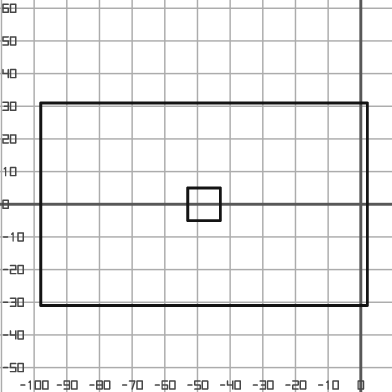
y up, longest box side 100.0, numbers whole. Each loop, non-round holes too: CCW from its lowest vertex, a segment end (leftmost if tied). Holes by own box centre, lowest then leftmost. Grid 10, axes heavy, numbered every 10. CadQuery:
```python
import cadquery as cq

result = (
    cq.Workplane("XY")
    .moveTo(-98.0, -31.0)
    .lineTo(2.0, -31.0)
    .lineTo(2.0, 31.0)
    .lineTo(-98.0, 31.0)
    .close()
    .moveTo(-53.0, -5.0)
    .lineTo(-43.0, -5.0)
    .lineTo(-43.0, 5.0)
    .lineTo(-53.0, 5.0)
    .close()
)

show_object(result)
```